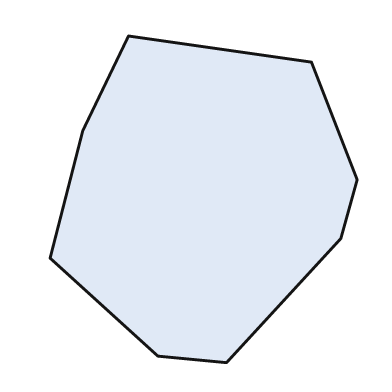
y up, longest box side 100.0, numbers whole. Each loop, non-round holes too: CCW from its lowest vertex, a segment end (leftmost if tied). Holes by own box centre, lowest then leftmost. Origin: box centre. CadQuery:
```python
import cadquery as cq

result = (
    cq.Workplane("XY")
    .moveTo(7.0, -50.0)
    .lineTo(42.0, -12.0)
    .lineTo(47.0, 6.0)
    .lineTo(33.0, 42.0)
    .lineTo(-23.0, 50.0)
    .lineTo(-37.0, 21.0)
    .lineTo(-47.0, -18.0)
    .lineTo(-14.0, -48.0)
    .close()
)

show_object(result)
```